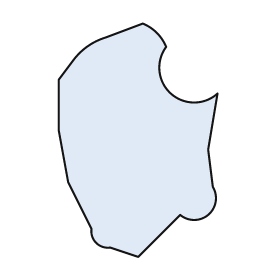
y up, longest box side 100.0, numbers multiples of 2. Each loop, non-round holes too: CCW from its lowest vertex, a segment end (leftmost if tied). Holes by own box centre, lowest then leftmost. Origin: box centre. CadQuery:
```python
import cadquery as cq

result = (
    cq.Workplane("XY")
    .moveTo(0.0, -50.0)
    .lineTo(18.0, -32.0)
    .threePointArc((30.0, -32.0), (32.0, -20.0))
    .lineTo(30.0, -4.0)
    .lineTo(34.0, 20.0)
    .threePointArc((14.0, 20.0), (12.0, 40.0))
    .threePointArc((8.0, 46.0), (2.0, 50.0))
    .lineTo(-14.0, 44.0)
    .threePointArc((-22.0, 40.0), (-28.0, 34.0))
    .lineTo(-34.0, 26.0)
    .lineTo(-34.0, 4.0)
    .lineTo(-30.0, -18.0)
    .lineTo(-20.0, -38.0)
    .threePointArc((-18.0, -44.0), (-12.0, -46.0))
    .close()
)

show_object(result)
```